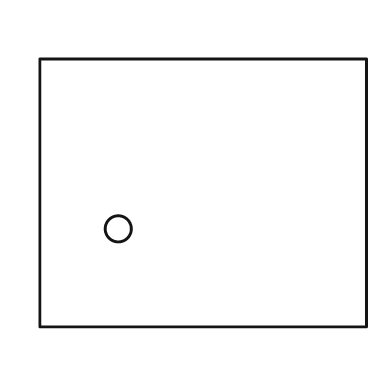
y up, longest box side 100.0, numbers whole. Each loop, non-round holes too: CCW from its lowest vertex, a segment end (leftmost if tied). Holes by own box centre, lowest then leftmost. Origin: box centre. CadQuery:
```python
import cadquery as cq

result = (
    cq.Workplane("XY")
    .moveTo(-50.0, -41.0)
    .lineTo(50.0, -41.0)
    .lineTo(50.0, 41.0)
    .lineTo(-50.0, 41.0)
    .close()
    .moveTo(-26.0, -11.0)
    .circle(4.0)
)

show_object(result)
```